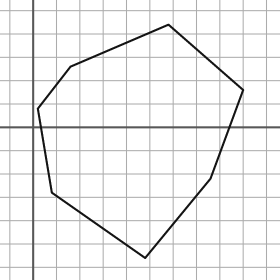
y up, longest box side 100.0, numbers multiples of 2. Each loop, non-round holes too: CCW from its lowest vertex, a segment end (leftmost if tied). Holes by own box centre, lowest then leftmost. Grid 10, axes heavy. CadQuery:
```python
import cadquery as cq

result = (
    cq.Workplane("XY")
    .moveTo(48.0, -56.0)
    .lineTo(76.0, -22.0)
    .lineTo(90.0, 16.0)
    .lineTo(58.0, 44.0)
    .lineTo(16.0, 26.0)
    .lineTo(2.0, 8.0)
    .lineTo(8.0, -28.0)
    .close()
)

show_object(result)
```